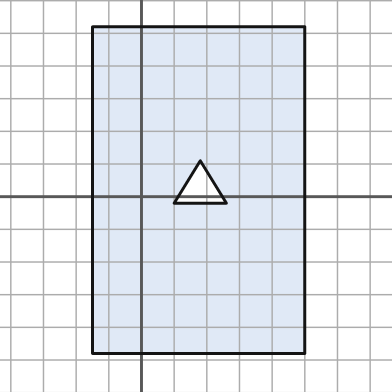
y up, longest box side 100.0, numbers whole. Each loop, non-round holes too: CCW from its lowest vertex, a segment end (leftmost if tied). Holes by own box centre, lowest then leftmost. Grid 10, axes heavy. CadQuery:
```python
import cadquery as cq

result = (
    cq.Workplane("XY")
    .moveTo(-15.0, -48.0)
    .lineTo(50.0, -48.0)
    .lineTo(50.0, 52.0)
    .lineTo(-15.0, 52.0)
    .close()
    .moveTo(10.0, -2.0)
    .lineTo(26.0, -2.0)
    .lineTo(18.0, 11.0)
    .close()
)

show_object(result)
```